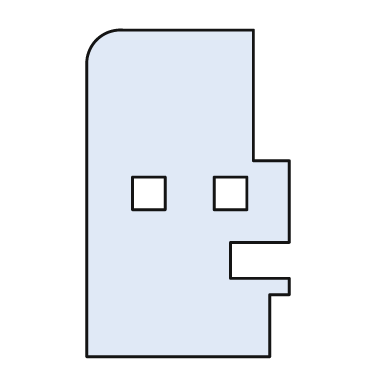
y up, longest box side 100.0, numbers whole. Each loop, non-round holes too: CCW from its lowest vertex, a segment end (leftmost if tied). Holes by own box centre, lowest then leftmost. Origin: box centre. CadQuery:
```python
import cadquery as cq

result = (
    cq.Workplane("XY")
    .moveTo(-31.0, -50.0)
    .lineTo(25.0, -50.0)
    .lineTo(25.0, -31.0)
    .lineTo(31.0, -31.0)
    .lineTo(31.0, -26.0)
    .lineTo(13.0, -26.0)
    .lineTo(13.0, -15.0)
    .lineTo(31.0, -15.0)
    .lineTo(31.0, 10.0)
    .lineTo(20.0, 10.0)
    .lineTo(20.0, 50.0)
    .lineTo(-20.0, 50.0)
    .threePointArc((-28.0, 47.0), (-31.0, 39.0))
    .close()
    .moveTo(-17.0, -5.0)
    .lineTo(-7.0, -5.0)
    .lineTo(-7.0, 5.0)
    .lineTo(-17.0, 5.0)
    .close()
    .moveTo(8.0, -5.0)
    .lineTo(18.0, -5.0)
    .lineTo(18.0, 5.0)
    .lineTo(8.0, 5.0)
    .close()
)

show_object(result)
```